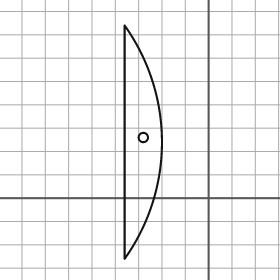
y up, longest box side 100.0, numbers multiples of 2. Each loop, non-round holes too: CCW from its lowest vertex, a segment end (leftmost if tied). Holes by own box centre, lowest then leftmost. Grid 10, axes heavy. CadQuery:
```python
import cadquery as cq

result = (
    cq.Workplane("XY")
    .moveTo(-36.0, -26.0)
    .threePointArc((-20.0, 24.0), (-36.0, 74.0))
    .close()
    .moveTo(-28.0, 26.0)
    .circle(2.0)
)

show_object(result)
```